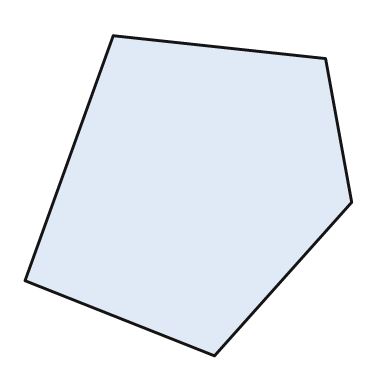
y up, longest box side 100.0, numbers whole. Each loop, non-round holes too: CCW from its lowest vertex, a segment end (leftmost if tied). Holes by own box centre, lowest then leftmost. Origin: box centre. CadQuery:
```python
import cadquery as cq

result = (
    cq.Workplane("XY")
    .moveTo(8.0, -49.0)
    .lineTo(50.0, -2.0)
    .lineTo(42.0, 42.0)
    .lineTo(-23.0, 49.0)
    .lineTo(-50.0, -26.0)
    .close()
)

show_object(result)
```